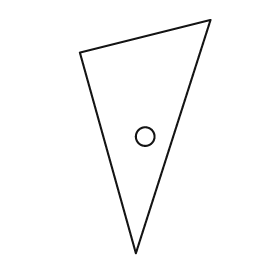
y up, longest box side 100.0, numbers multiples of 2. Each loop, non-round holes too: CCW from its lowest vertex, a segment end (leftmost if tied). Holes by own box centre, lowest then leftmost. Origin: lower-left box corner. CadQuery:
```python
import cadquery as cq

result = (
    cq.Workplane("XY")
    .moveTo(24.0, 0.0)
    .lineTo(56.0, 100.0)
    .lineTo(0.0, 86.0)
    .close()
    .moveTo(28.0, 50.0)
    .circle(4.0)
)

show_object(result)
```